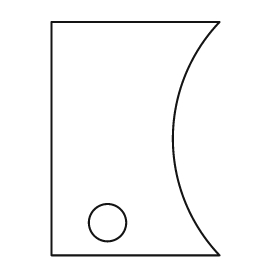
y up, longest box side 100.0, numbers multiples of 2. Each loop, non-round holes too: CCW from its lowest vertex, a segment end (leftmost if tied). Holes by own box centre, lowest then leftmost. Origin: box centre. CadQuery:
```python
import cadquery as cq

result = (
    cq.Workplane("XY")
    .moveTo(-36.0, -50.0)
    .lineTo(36.0, -50.0)
    .threePointArc((16.0, 0.0), (36.0, 50.0))
    .lineTo(-36.0, 50.0)
    .close()
    .moveTo(-12.0, -36.0)
    .circle(8.0)
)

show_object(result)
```